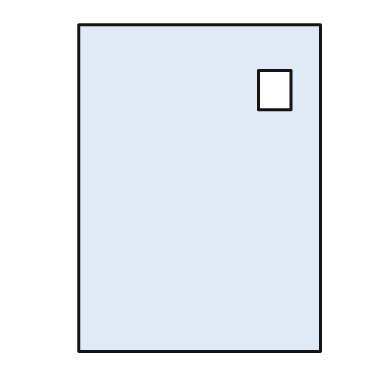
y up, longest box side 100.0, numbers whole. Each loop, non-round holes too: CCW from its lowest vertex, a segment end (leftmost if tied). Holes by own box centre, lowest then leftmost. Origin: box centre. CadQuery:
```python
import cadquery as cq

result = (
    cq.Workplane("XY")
    .moveTo(-37.0, -50.0)
    .lineTo(37.0, -50.0)
    .lineTo(37.0, 50.0)
    .lineTo(-37.0, 50.0)
    .close()
    .moveTo(18.0, 24.0)
    .lineTo(28.0, 24.0)
    .lineTo(28.0, 36.0)
    .lineTo(18.0, 36.0)
    .close()
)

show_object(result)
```